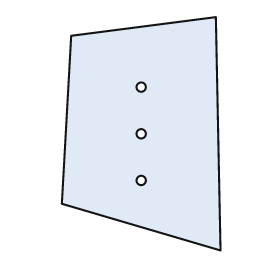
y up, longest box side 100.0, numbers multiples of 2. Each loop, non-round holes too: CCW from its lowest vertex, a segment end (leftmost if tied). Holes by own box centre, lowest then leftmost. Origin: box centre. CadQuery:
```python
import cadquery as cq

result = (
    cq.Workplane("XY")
    .moveTo(34.0, -50.0)
    .lineTo(32.0, 50.0)
    .lineTo(-30.0, 42.0)
    .lineTo(-34.0, -30.0)
    .close()
    .moveTo(0.0, -20.0)
    .circle(2.0)
    .moveTo(0.0, 0.0)
    .circle(2.0)
    .moveTo(0.0, 20.0)
    .circle(2.0)
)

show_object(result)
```